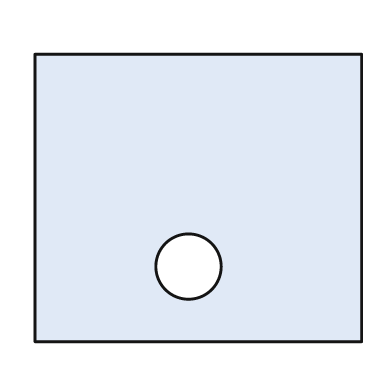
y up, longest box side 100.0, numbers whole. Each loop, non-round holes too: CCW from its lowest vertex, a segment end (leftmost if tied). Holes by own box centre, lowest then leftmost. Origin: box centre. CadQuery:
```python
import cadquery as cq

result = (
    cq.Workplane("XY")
    .moveTo(-50.0, -44.0)
    .lineTo(50.0, -44.0)
    .lineTo(50.0, 44.0)
    .lineTo(-50.0, 44.0)
    .close()
    .moveTo(-3.0, -21.0)
    .circle(10.0)
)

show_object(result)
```